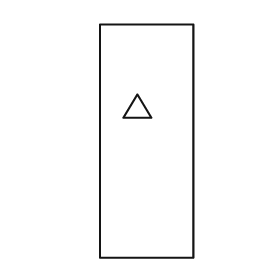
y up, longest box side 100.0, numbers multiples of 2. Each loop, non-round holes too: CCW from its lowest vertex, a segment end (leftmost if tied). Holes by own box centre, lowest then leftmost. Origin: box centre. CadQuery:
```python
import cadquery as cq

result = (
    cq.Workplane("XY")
    .moveTo(-20.0, -50.0)
    .lineTo(20.0, -50.0)
    .lineTo(20.0, 50.0)
    .lineTo(-20.0, 50.0)
    .close()
    .moveTo(-10.0, 10.0)
    .lineTo(2.0, 10.0)
    .lineTo(-4.0, 20.0)
    .close()
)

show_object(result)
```